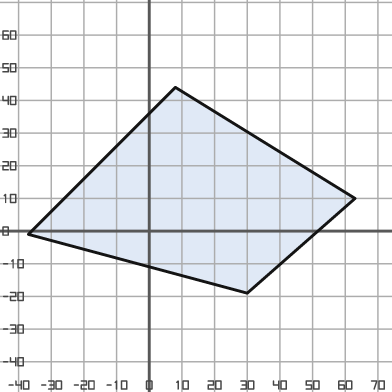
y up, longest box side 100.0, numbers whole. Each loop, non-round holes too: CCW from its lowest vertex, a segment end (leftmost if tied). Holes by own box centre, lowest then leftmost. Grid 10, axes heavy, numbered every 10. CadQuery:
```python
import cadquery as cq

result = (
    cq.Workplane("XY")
    .moveTo(30.0, -19.0)
    .lineTo(63.0, 10.0)
    .lineTo(8.0, 44.0)
    .lineTo(-37.0, -1.0)
    .close()
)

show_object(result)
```